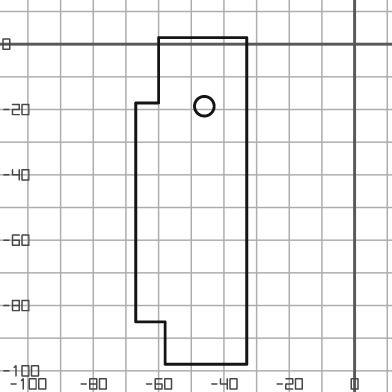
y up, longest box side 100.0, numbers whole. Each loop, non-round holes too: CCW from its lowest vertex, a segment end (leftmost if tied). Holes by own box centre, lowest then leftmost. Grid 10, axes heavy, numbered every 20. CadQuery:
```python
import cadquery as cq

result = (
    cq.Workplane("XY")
    .moveTo(-58.0, -98.0)
    .lineTo(-33.0, -98.0)
    .lineTo(-33.0, 2.0)
    .lineTo(-60.0, 2.0)
    .lineTo(-60.0, -18.0)
    .lineTo(-67.0, -18.0)
    .lineTo(-67.0, -85.0)
    .lineTo(-58.0, -85.0)
    .close()
    .moveTo(-46.0, -19.0)
    .circle(3.0)
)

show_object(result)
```